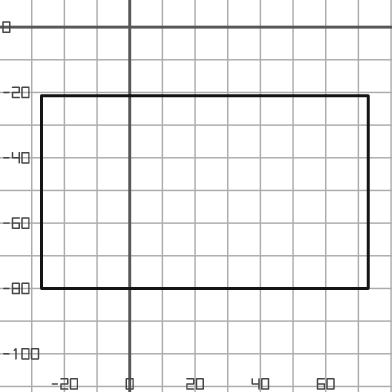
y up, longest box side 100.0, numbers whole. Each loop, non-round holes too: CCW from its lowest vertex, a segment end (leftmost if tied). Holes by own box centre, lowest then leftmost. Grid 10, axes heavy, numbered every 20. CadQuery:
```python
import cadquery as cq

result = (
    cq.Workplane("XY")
    .moveTo(-27.0, -80.0)
    .lineTo(73.0, -80.0)
    .lineTo(73.0, -21.0)
    .lineTo(-27.0, -21.0)
    .close()
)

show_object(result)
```